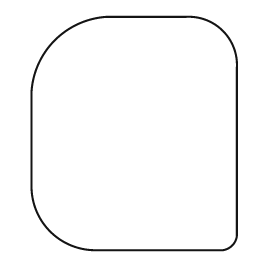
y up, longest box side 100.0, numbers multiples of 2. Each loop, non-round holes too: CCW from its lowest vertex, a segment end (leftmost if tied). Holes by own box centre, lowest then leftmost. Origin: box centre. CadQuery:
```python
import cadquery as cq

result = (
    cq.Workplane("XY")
    .moveTo(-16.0, -50.0)
    .lineTo(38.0, -50.0)
    .threePointArc((42.0, -48.0), (44.0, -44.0))
    .lineTo(44.0, 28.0)
    .threePointArc((38.0, 44.0), (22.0, 50.0))
    .lineTo(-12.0, 50.0)
    .threePointArc((-34.0, 40.0), (-44.0, 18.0))
    .lineTo(-44.0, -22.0)
    .threePointArc((-36.0, -42.0), (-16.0, -50.0))
    .close()
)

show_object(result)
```